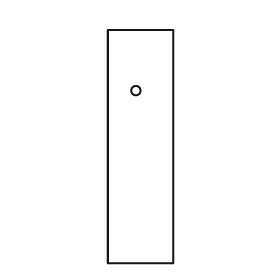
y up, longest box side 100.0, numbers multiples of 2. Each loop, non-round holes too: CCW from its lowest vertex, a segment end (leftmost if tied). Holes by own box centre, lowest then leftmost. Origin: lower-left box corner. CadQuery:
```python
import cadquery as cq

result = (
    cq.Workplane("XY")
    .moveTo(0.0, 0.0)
    .lineTo(28.0, 0.0)
    .lineTo(28.0, 100.0)
    .lineTo(0.0, 100.0)
    .close()
    .moveTo(12.0, 74.0)
    .circle(2.0)
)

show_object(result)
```